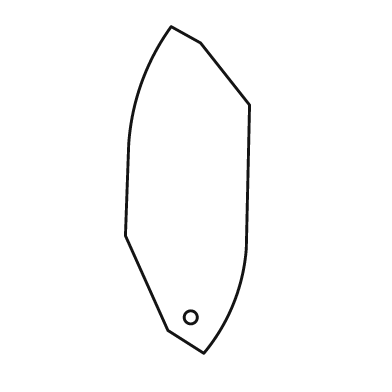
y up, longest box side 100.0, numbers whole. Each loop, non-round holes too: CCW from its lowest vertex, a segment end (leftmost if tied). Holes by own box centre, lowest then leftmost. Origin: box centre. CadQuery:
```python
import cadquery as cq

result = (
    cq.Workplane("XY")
    .moveTo(5.0, -50.0)
    .threePointArc((14.0, -35.0), (18.0, -18.0))
    .lineTo(19.0, 26.0)
    .lineTo(4.0, 45.0)
    .lineTo(-5.0, 50.0)
    .threePointArc((-14.0, 33.0), (-18.0, 14.0))
    .lineTo(-19.0, -14.0)
    .lineTo(-6.0, -43.0)
    .close()
    .moveTo(1.0, -39.0)
    .circle(2.0)
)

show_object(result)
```